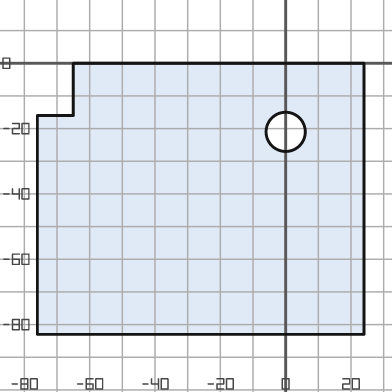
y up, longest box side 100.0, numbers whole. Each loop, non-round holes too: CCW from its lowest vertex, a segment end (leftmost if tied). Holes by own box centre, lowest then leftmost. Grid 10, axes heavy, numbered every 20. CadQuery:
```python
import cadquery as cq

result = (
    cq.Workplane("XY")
    .moveTo(-76.0, -83.0)
    .lineTo(24.0, -83.0)
    .lineTo(24.0, 0.0)
    .lineTo(-65.0, 0.0)
    .lineTo(-65.0, -16.0)
    .lineTo(-76.0, -16.0)
    .close()
    .moveTo(0.0, -21.0)
    .circle(6.0)
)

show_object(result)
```